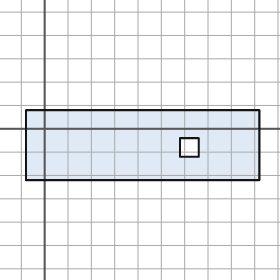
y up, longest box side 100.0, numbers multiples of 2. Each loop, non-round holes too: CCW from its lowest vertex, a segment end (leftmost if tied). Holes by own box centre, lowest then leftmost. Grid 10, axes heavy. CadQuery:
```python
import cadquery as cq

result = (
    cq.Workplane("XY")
    .moveTo(-8.0, -22.0)
    .lineTo(92.0, -22.0)
    .lineTo(92.0, 8.0)
    .lineTo(-8.0, 8.0)
    .close()
    .moveTo(58.0, -12.0)
    .lineTo(66.0, -12.0)
    .lineTo(66.0, -4.0)
    .lineTo(58.0, -4.0)
    .close()
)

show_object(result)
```